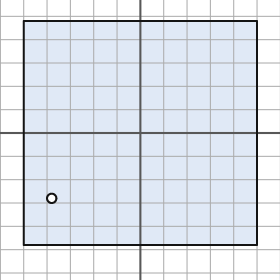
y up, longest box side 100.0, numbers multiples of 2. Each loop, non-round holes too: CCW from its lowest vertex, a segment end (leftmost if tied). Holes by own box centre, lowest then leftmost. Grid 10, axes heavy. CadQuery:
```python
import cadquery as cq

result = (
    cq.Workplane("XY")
    .moveTo(-50.0, -48.0)
    .lineTo(50.0, -48.0)
    .lineTo(50.0, 48.0)
    .lineTo(-50.0, 48.0)
    .close()
    .moveTo(-38.0, -28.0)
    .circle(2.0)
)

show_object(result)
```